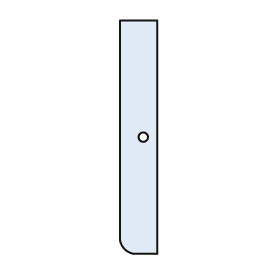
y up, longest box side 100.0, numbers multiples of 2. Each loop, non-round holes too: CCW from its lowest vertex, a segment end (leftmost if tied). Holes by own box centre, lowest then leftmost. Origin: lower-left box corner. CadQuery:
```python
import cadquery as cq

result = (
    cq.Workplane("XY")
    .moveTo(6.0, 0.0)
    .lineTo(16.0, 0.0)
    .lineTo(16.0, 100.0)
    .lineTo(0.0, 100.0)
    .lineTo(0.0, 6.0)
    .threePointArc((2.0, 2.0), (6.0, 0.0))
    .close()
    .moveTo(10.0, 50.0)
    .circle(2.0)
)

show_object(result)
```